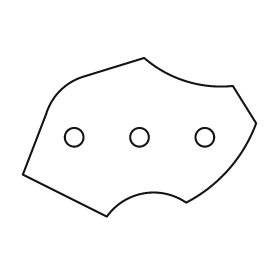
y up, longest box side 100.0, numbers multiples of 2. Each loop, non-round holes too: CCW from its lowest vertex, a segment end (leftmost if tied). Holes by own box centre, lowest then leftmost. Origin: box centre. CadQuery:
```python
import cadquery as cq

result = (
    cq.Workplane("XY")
    .moveTo(-14.0, -34.0)
    .threePointArc((2.0, -24.0), (20.0, -28.0))
    .threePointArc((38.0, -14.0), (50.0, 6.0))
    .lineTo(40.0, 22.0)
    .threePointArc((20.0, 24.0), (2.0, 34.0))
    .lineTo(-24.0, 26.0)
    .threePointArc((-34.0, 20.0), (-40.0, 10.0))
    .lineTo(-50.0, -16.0)
    .close()
    .moveTo(-28.0, 0.0)
    .circle(4.0)
    .moveTo(0.0, 0.0)
    .circle(4.0)
    .moveTo(28.0, 0.0)
    .circle(4.0)
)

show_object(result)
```